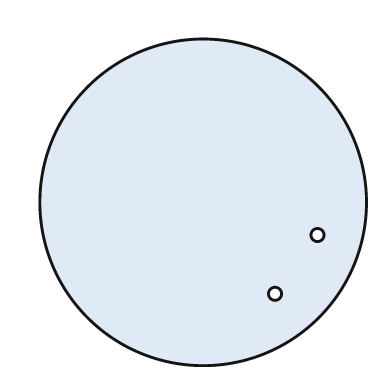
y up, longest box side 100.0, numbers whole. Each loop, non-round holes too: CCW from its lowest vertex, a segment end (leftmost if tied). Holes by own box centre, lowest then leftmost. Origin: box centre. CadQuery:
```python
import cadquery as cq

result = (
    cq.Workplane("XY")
    .moveTo(0.0, 0.0)
    .circle(50.0)
    .moveTo(22.0, -28.0)
    .circle(2.0)
    .moveTo(35.0, -10.0)
    .circle(2.0)
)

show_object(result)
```